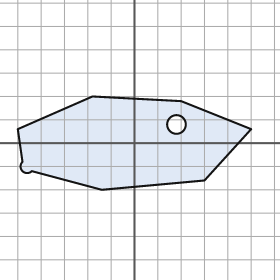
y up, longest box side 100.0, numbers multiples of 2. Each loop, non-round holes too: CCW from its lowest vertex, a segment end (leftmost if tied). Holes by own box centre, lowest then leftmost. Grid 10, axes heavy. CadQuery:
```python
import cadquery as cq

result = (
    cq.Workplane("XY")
    .moveTo(-14.0, -20.0)
    .lineTo(30.0, -16.0)
    .lineTo(50.0, 6.0)
    .lineTo(20.0, 18.0)
    .lineTo(-18.0, 20.0)
    .lineTo(-50.0, 6.0)
    .lineTo(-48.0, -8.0)
    .threePointArc((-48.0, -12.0), (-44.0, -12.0))
    .close()
    .moveTo(18.0, 8.0)
    .circle(4.0)
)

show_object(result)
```